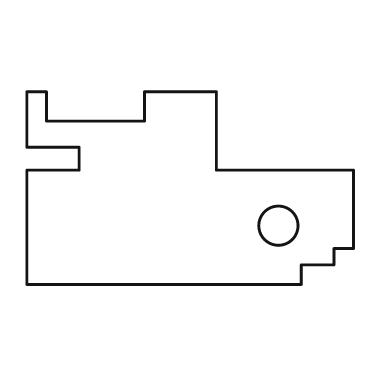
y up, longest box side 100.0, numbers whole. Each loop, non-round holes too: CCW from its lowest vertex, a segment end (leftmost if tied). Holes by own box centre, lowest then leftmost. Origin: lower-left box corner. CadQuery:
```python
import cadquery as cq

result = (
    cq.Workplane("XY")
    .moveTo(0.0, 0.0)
    .lineTo(84.0, 0.0)
    .lineTo(84.0, 6.0)
    .lineTo(94.0, 6.0)
    .lineTo(94.0, 11.0)
    .lineTo(100.0, 11.0)
    .lineTo(100.0, 35.0)
    .lineTo(58.0, 35.0)
    .lineTo(58.0, 59.0)
    .lineTo(36.0, 59.0)
    .lineTo(36.0, 50.0)
    .lineTo(6.0, 50.0)
    .lineTo(6.0, 59.0)
    .lineTo(0.0, 59.0)
    .lineTo(0.0, 42.0)
    .lineTo(16.0, 42.0)
    .lineTo(16.0, 35.0)
    .lineTo(0.0, 35.0)
    .close()
    .moveTo(77.0, 18.0)
    .circle(6.0)
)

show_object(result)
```